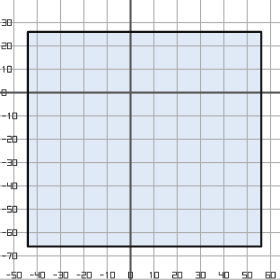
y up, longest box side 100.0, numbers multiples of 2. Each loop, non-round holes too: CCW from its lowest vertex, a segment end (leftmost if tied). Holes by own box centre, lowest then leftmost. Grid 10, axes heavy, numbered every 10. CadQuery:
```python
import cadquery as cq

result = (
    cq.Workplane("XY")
    .moveTo(-44.0, -66.0)
    .lineTo(56.0, -66.0)
    .lineTo(56.0, 26.0)
    .lineTo(-44.0, 26.0)
    .close()
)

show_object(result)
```